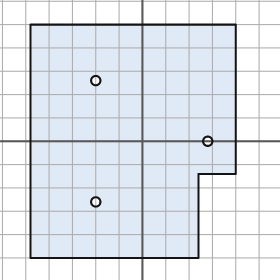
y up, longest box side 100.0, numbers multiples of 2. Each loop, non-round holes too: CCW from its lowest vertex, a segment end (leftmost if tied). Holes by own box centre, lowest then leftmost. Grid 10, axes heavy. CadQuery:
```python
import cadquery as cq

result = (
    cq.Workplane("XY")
    .moveTo(-48.0, -50.0)
    .lineTo(24.0, -50.0)
    .lineTo(24.0, -14.0)
    .lineTo(40.0, -14.0)
    .lineTo(40.0, 50.0)
    .lineTo(-48.0, 50.0)
    .close()
    .moveTo(-20.0, -26.0)
    .circle(2.0)
    .moveTo(28.0, 0.0)
    .circle(2.0)
    .moveTo(-20.0, 26.0)
    .circle(2.0)
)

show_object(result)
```